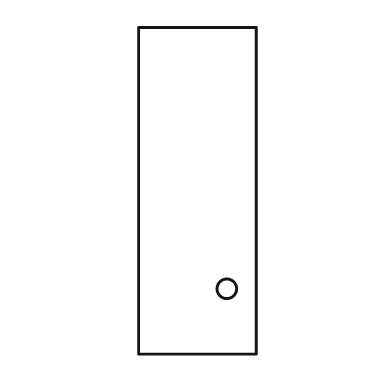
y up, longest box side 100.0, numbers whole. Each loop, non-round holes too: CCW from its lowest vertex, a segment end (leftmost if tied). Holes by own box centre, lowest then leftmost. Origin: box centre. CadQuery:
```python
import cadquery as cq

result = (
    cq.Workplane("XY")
    .moveTo(-18.0, -50.0)
    .lineTo(18.0, -50.0)
    .lineTo(18.0, 50.0)
    .lineTo(-18.0, 50.0)
    .close()
    .moveTo(9.0, -30.0)
    .circle(3.0)
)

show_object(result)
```